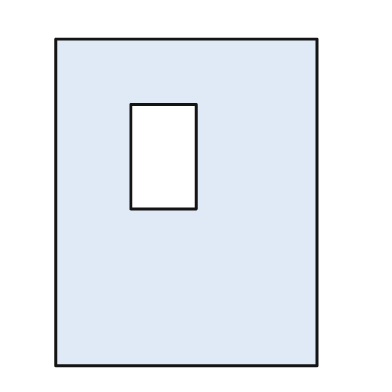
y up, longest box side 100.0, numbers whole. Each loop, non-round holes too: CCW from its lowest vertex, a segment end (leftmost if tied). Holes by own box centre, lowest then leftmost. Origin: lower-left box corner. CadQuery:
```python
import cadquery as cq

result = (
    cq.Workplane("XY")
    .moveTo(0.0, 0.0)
    .lineTo(80.0, 0.0)
    .lineTo(80.0, 100.0)
    .lineTo(0.0, 100.0)
    .close()
    .moveTo(23.0, 48.0)
    .lineTo(43.0, 48.0)
    .lineTo(43.0, 80.0)
    .lineTo(23.0, 80.0)
    .close()
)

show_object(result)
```